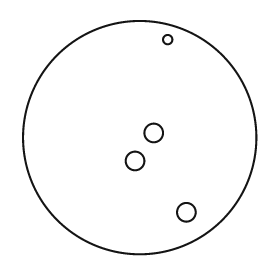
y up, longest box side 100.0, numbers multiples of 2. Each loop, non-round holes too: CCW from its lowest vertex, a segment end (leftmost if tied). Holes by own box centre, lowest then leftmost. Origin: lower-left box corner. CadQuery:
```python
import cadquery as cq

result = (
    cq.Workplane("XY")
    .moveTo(50.0, 50.0)
    .circle(50.0)
    .moveTo(70.0, 18.0)
    .circle(4.0)
    .moveTo(48.0, 40.0)
    .circle(4.0)
    .moveTo(56.0, 52.0)
    .circle(4.0)
    .moveTo(62.0, 92.0)
    .circle(2.0)
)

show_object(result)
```